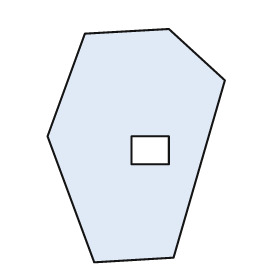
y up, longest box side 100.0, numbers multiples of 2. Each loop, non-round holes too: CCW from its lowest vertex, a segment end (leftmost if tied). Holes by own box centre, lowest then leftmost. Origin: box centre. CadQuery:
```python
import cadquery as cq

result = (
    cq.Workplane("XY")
    .moveTo(-18.0, -50.0)
    .lineTo(16.0, -48.0)
    .lineTo(38.0, 28.0)
    .lineTo(14.0, 50.0)
    .lineTo(-22.0, 48.0)
    .lineTo(-38.0, 4.0)
    .close()
    .moveTo(-2.0, -8.0)
    .lineTo(14.0, -8.0)
    .lineTo(14.0, 4.0)
    .lineTo(-2.0, 4.0)
    .close()
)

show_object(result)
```